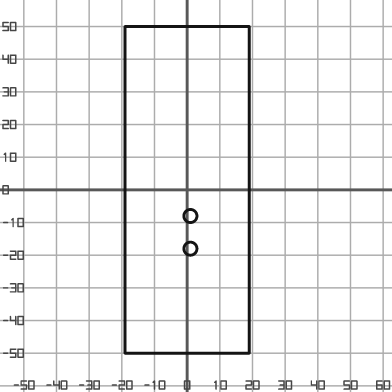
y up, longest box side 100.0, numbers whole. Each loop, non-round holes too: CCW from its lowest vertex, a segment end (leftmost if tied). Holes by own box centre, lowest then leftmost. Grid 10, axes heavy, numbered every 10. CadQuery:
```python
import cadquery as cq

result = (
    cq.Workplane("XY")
    .moveTo(-19.0, -50.0)
    .lineTo(19.0, -50.0)
    .lineTo(19.0, 50.0)
    .lineTo(-19.0, 50.0)
    .close()
    .moveTo(1.0, -18.0)
    .circle(2.0)
    .moveTo(1.0, -8.0)
    .circle(2.0)
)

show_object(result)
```